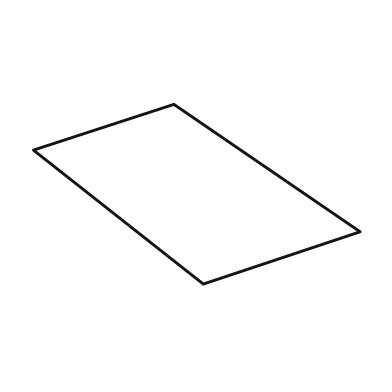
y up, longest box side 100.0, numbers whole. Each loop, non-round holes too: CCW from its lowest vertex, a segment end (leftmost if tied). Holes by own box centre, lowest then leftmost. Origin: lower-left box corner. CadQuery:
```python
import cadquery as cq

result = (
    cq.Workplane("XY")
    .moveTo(52.0, 0.0)
    .lineTo(100.0, 16.0)
    .lineTo(43.0, 55.0)
    .lineTo(0.0, 41.0)
    .close()
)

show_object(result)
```